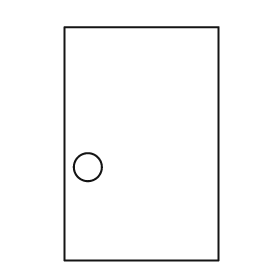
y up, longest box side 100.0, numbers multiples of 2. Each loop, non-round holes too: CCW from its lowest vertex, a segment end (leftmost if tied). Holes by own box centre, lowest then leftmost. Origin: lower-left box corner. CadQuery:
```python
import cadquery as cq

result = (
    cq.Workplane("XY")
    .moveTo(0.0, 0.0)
    .lineTo(66.0, 0.0)
    .lineTo(66.0, 100.0)
    .lineTo(0.0, 100.0)
    .close()
    .moveTo(10.0, 40.0)
    .circle(6.0)
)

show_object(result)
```